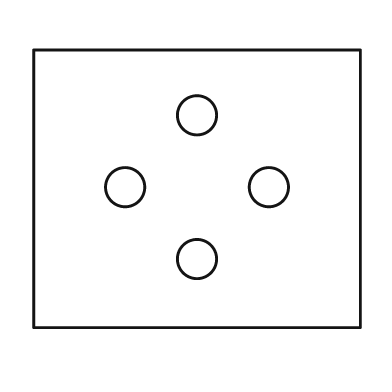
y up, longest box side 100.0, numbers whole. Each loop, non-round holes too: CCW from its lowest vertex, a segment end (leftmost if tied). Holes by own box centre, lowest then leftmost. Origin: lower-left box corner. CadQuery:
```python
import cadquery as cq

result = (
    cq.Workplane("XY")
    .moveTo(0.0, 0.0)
    .lineTo(100.0, 0.0)
    .lineTo(100.0, 85.0)
    .lineTo(0.0, 85.0)
    .close()
    .moveTo(50.0, 21.0)
    .circle(6.0)
    .moveTo(28.0, 43.0)
    .circle(6.0)
    .moveTo(72.0, 43.0)
    .circle(6.0)
    .moveTo(50.0, 65.0)
    .circle(6.0)
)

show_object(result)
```